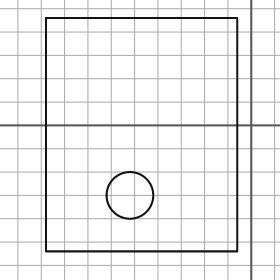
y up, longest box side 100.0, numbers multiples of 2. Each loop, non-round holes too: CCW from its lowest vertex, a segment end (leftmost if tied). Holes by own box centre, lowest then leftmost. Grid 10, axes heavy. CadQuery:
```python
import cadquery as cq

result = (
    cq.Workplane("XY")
    .moveTo(-88.0, -54.0)
    .lineTo(-6.0, -54.0)
    .lineTo(-6.0, 46.0)
    .lineTo(-88.0, 46.0)
    .close()
    .moveTo(-52.0, -30.0)
    .circle(10.0)
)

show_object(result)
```